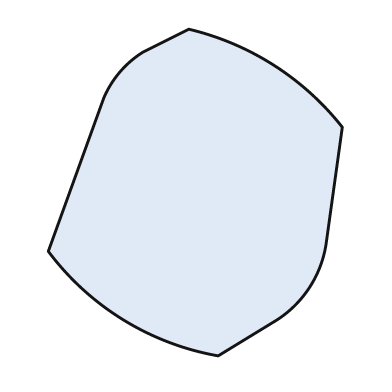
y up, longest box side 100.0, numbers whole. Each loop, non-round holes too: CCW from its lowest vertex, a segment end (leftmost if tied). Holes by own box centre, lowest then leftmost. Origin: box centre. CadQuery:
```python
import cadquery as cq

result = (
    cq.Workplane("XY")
    .moveTo(7.0, -50.0)
    .lineTo(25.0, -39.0)
    .threePointArc((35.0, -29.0), (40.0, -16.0))
    .lineTo(45.0, 20.0)
    .threePointArc((24.0, 39.0), (-2.0, 50.0))
    .lineTo(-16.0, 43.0)
    .threePointArc((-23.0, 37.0), (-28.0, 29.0))
    .lineTo(-45.0, -18.0)
    .threePointArc((-22.0, -39.0), (7.0, -50.0))
    .close()
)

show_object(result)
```